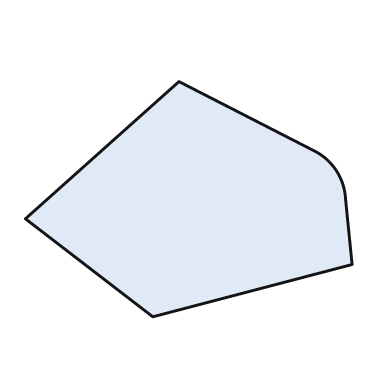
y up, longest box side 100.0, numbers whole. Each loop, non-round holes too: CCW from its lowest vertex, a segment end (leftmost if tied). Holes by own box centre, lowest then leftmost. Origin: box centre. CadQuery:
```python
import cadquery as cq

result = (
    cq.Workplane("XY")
    .moveTo(-11.0, -36.0)
    .lineTo(50.0, -20.0)
    .lineTo(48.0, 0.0)
    .threePointArc((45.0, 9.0), (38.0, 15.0))
    .lineTo(-3.0, 36.0)
    .lineTo(-50.0, -6.0)
    .close()
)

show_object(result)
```